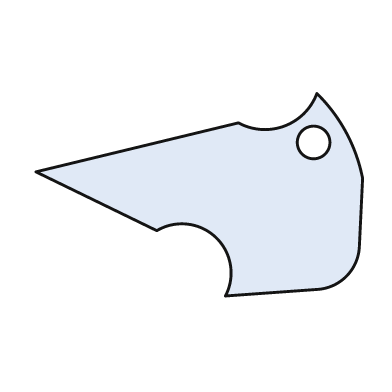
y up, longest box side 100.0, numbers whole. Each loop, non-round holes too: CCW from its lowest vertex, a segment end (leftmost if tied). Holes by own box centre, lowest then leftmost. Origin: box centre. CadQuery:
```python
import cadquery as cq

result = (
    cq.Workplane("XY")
    .moveTo(8.0, -31.0)
    .lineTo(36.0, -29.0)
    .threePointArc((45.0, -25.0), (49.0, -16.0))
    .lineTo(50.0, 5.0)
    .threePointArc((45.0, 19.0), (36.0, 31.0))
    .threePointArc((26.0, 21.0), (12.0, 22.0))
    .lineTo(-50.0, 7.0)
    .lineTo(-13.0, -11.0)
    .threePointArc((5.0, -13.0), (8.0, -31.0))
    .close()
    .moveTo(35.0, 16.0)
    .circle(5.0)
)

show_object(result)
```